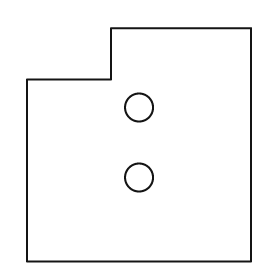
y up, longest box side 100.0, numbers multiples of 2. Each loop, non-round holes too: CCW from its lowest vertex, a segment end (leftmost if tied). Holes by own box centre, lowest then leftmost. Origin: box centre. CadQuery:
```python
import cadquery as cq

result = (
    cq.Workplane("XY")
    .moveTo(-48.0, -50.0)
    .lineTo(48.0, -50.0)
    .lineTo(48.0, 50.0)
    .lineTo(-12.0, 50.0)
    .lineTo(-12.0, 28.0)
    .lineTo(-48.0, 28.0)
    .close()
    .moveTo(0.0, -14.0)
    .circle(6.0)
    .moveTo(0.0, 16.0)
    .circle(6.0)
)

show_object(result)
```